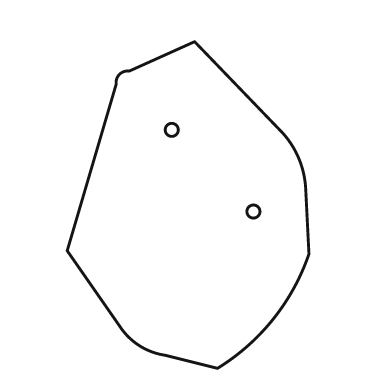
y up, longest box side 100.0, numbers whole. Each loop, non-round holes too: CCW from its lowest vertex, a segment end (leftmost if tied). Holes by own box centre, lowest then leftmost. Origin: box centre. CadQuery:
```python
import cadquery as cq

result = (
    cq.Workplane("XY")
    .moveTo(9.0, -50.0)
    .threePointArc((26.0, -35.0), (37.0, -15.0))
    .lineTo(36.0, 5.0)
    .threePointArc((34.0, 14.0), (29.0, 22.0))
    .lineTo(2.0, 50.0)
    .lineTo(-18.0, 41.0)
    .threePointArc((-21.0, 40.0), (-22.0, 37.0))
    .lineTo(-37.0, -14.0)
    .lineTo(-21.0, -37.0)
    .threePointArc((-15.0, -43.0), (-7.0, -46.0))
    .close()
    .moveTo(20.0, -2.0)
    .circle(2.0)
    .moveTo(-5.0, 23.0)
    .circle(2.0)
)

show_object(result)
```